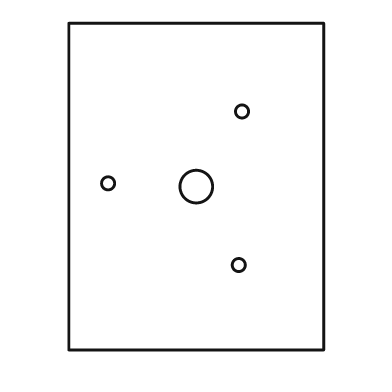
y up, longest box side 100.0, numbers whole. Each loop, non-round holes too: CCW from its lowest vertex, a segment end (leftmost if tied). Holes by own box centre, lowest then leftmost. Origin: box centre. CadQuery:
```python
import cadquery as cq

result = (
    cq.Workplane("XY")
    .moveTo(-39.0, -50.0)
    .lineTo(39.0, -50.0)
    .lineTo(39.0, 50.0)
    .lineTo(-39.0, 50.0)
    .close()
    .moveTo(13.0, -24.0)
    .circle(2.0)
    .moveTo(0.0, 0.0)
    .circle(5.0)
    .moveTo(-27.0, 1.0)
    .circle(2.0)
    .moveTo(14.0, 23.0)
    .circle(2.0)
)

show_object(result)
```